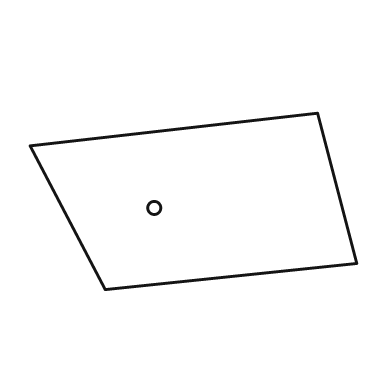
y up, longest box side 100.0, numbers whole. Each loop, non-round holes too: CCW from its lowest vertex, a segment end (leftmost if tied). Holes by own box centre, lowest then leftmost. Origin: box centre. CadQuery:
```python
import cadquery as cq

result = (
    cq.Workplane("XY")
    .moveTo(-27.0, -27.0)
    .lineTo(50.0, -19.0)
    .lineTo(38.0, 27.0)
    .lineTo(-50.0, 17.0)
    .close()
    .moveTo(-12.0, -2.0)
    .circle(2.0)
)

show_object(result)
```